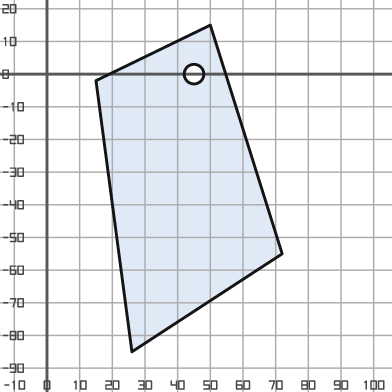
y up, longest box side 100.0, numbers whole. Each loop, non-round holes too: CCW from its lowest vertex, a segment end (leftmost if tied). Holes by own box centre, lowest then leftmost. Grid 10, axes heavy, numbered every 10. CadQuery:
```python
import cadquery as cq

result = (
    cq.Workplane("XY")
    .moveTo(26.0, -85.0)
    .lineTo(72.0, -55.0)
    .lineTo(50.0, 15.0)
    .lineTo(15.0, -2.0)
    .close()
    .moveTo(45.0, 0.0)
    .circle(3.0)
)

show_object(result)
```